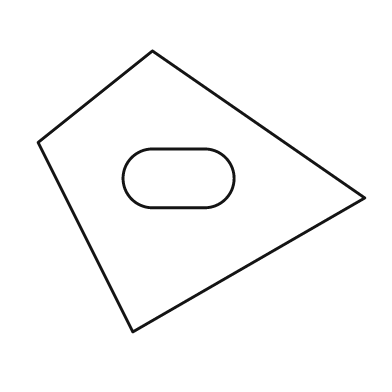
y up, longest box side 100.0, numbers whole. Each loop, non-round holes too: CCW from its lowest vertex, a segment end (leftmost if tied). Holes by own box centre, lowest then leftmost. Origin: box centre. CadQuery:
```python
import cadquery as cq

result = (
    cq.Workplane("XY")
    .moveTo(-21.0, -43.0)
    .lineTo(50.0, -2.0)
    .lineTo(-15.0, 43.0)
    .lineTo(-50.0, 15.0)
    .close()
    .moveTo(-15.0, -5.0)
    .lineTo(1.0, -5.0)
    .threePointArc((10.0, 4.0), (1.0, 13.0))
    .lineTo(-15.0, 13.0)
    .threePointArc((-24.0, 4.0), (-15.0, -5.0))
    .close()
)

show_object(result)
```